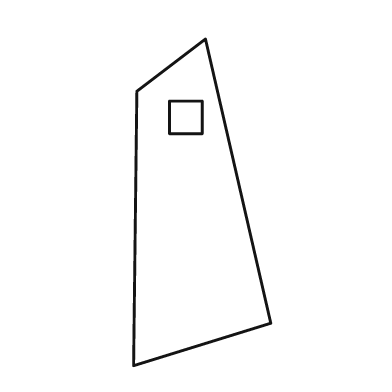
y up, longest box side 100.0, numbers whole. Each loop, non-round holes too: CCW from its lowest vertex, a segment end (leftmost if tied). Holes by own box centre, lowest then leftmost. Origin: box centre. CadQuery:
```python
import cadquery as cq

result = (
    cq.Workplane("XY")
    .moveTo(-21.0, -50.0)
    .lineTo(21.0, -37.0)
    .lineTo(1.0, 50.0)
    .lineTo(-20.0, 34.0)
    .close()
    .moveTo(-10.0, 21.0)
    .lineTo(0.0, 21.0)
    .lineTo(0.0, 31.0)
    .lineTo(-10.0, 31.0)
    .close()
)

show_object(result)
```